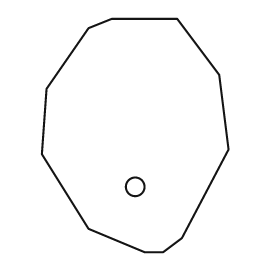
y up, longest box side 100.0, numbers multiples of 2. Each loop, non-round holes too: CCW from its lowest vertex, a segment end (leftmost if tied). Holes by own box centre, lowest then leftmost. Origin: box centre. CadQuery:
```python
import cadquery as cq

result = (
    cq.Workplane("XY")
    .moveTo(4.0, -50.0)
    .lineTo(12.0, -50.0)
    .lineTo(20.0, -44.0)
    .lineTo(40.0, -6.0)
    .lineTo(36.0, 26.0)
    .lineTo(18.0, 50.0)
    .lineTo(-10.0, 50.0)
    .lineTo(-20.0, 46.0)
    .lineTo(-38.0, 20.0)
    .lineTo(-40.0, -8.0)
    .lineTo(-20.0, -40.0)
    .close()
    .moveTo(0.0, -22.0)
    .circle(4.0)
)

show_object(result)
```